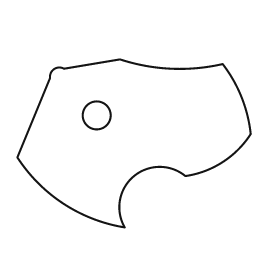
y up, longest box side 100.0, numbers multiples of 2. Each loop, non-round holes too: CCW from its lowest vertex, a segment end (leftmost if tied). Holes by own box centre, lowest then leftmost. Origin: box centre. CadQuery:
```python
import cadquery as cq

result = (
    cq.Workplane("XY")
    .moveTo(-4.0, -36.0)
    .threePointArc((0.0, -14.0), (22.0, -14.0))
    .threePointArc((38.0, -8.0), (50.0, 4.0))
    .threePointArc((46.0, 20.0), (38.0, 34.0))
    .threePointArc((16.0, 32.0), (-6.0, 36.0))
    .lineTo(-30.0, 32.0)
    .threePointArc((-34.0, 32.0), (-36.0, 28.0))
    .lineTo(-50.0, -6.0)
    .threePointArc((-30.0, -26.0), (-4.0, -36.0))
    .close()
    .moveTo(-16.0, 12.0)
    .circle(6.0)
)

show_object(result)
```